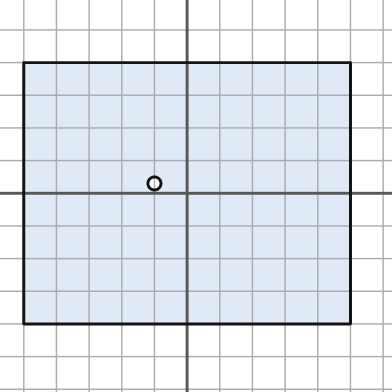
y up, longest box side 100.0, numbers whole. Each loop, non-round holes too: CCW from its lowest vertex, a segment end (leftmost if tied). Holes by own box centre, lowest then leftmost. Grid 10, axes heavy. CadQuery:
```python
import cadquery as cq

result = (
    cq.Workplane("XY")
    .moveTo(-50.0, -40.0)
    .lineTo(50.0, -40.0)
    .lineTo(50.0, 40.0)
    .lineTo(-50.0, 40.0)
    .close()
    .moveTo(-10.0, 3.0)
    .circle(2.0)
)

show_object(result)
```